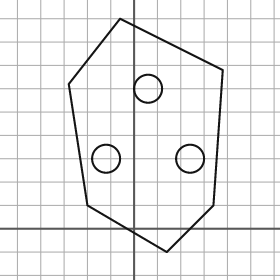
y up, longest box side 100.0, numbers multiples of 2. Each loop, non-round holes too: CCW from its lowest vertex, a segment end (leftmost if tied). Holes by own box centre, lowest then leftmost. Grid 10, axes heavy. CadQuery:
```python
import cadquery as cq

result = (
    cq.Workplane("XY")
    .moveTo(14.0, -10.0)
    .lineTo(34.0, 10.0)
    .lineTo(38.0, 68.0)
    .lineTo(-6.0, 90.0)
    .lineTo(-28.0, 62.0)
    .lineTo(-20.0, 10.0)
    .close()
    .moveTo(-12.0, 30.0)
    .circle(6.0)
    .moveTo(24.0, 30.0)
    .circle(6.0)
    .moveTo(6.0, 60.0)
    .circle(6.0)
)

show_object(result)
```